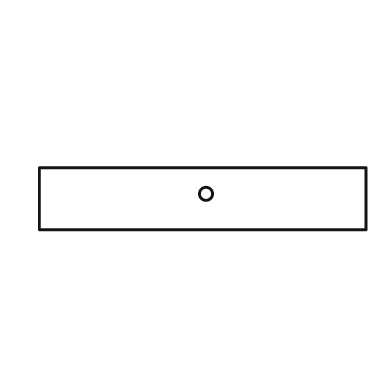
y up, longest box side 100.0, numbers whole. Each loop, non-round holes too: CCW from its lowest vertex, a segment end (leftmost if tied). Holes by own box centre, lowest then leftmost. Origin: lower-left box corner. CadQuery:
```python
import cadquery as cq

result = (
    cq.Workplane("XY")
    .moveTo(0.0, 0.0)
    .lineTo(100.0, 0.0)
    .lineTo(100.0, 19.0)
    .lineTo(0.0, 19.0)
    .close()
    .moveTo(51.0, 11.0)
    .circle(2.0)
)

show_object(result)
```